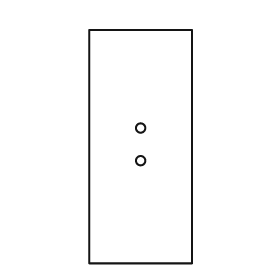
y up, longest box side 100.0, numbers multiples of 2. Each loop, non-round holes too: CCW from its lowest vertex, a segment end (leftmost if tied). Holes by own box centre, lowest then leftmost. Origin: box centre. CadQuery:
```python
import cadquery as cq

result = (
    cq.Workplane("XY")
    .moveTo(-22.0, -50.0)
    .lineTo(22.0, -50.0)
    .lineTo(22.0, 50.0)
    .lineTo(-22.0, 50.0)
    .close()
    .moveTo(0.0, -6.0)
    .circle(2.0)
    .moveTo(0.0, 8.0)
    .circle(2.0)
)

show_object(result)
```